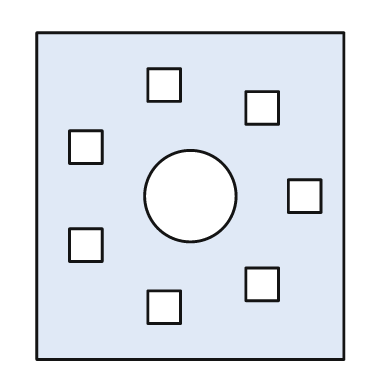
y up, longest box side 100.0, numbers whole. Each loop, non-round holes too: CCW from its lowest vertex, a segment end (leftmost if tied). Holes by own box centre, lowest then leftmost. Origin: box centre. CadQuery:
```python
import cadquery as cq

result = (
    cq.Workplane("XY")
    .moveTo(-47.0, -50.0)
    .lineTo(47.0, -50.0)
    .lineTo(47.0, 50.0)
    .lineTo(-47.0, 50.0)
    .close()
    .moveTo(-13.0, -39.0)
    .lineTo(-3.0, -39.0)
    .lineTo(-3.0, -29.0)
    .lineTo(-13.0, -29.0)
    .close()
    .moveTo(17.0, -32.0)
    .lineTo(27.0, -32.0)
    .lineTo(27.0, -22.0)
    .lineTo(17.0, -22.0)
    .close()
    .moveTo(-37.0, -20.0)
    .lineTo(-27.0, -20.0)
    .lineTo(-27.0, -10.0)
    .lineTo(-37.0, -10.0)
    .close()
    .moveTo(0.0, 0.0)
    .circle(14.0)
    .moveTo(30.0, -5.0)
    .lineTo(40.0, -5.0)
    .lineTo(40.0, 5.0)
    .lineTo(30.0, 5.0)
    .close()
    .moveTo(-37.0, 10.0)
    .lineTo(-27.0, 10.0)
    .lineTo(-27.0, 20.0)
    .lineTo(-37.0, 20.0)
    .close()
    .moveTo(17.0, 22.0)
    .lineTo(27.0, 22.0)
    .lineTo(27.0, 32.0)
    .lineTo(17.0, 32.0)
    .close()
    .moveTo(-13.0, 29.0)
    .lineTo(-3.0, 29.0)
    .lineTo(-3.0, 39.0)
    .lineTo(-13.0, 39.0)
    .close()
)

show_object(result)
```